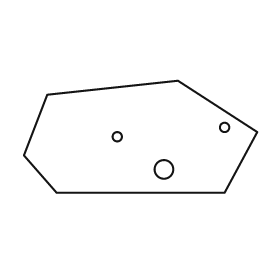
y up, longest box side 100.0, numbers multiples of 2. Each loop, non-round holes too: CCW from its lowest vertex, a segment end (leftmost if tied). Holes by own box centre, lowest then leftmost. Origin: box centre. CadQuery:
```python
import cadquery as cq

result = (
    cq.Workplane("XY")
    .moveTo(-36.0, -24.0)
    .lineTo(36.0, -24.0)
    .lineTo(50.0, 2.0)
    .lineTo(16.0, 24.0)
    .lineTo(-40.0, 18.0)
    .lineTo(-50.0, -8.0)
    .close()
    .moveTo(10.0, -14.0)
    .circle(4.0)
    .moveTo(-10.0, 0.0)
    .circle(2.0)
    .moveTo(36.0, 4.0)
    .circle(2.0)
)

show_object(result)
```